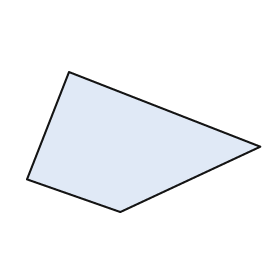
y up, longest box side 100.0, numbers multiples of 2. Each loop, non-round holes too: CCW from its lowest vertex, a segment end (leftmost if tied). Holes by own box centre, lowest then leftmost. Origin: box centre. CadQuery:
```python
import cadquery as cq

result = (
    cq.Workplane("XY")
    .moveTo(-10.0, -30.0)
    .lineTo(50.0, -2.0)
    .lineTo(-32.0, 30.0)
    .lineTo(-50.0, -16.0)
    .close()
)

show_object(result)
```